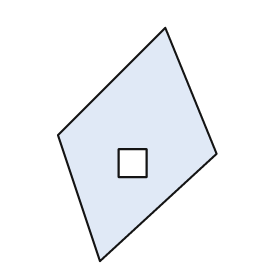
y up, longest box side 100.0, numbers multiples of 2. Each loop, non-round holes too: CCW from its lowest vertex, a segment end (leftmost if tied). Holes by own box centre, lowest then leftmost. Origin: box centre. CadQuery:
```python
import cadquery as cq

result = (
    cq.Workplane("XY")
    .moveTo(-16.0, -50.0)
    .lineTo(34.0, -4.0)
    .lineTo(12.0, 50.0)
    .lineTo(-34.0, 4.0)
    .close()
    .moveTo(-8.0, -14.0)
    .lineTo(4.0, -14.0)
    .lineTo(4.0, -2.0)
    .lineTo(-8.0, -2.0)
    .close()
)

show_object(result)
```